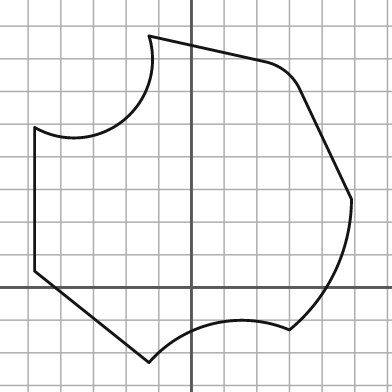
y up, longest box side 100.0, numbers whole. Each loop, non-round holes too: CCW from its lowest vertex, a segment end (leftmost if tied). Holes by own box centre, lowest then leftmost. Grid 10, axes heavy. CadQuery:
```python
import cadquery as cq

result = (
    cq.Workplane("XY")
    .moveTo(-13.0, -23.0)
    .threePointArc((7.0, -11.0), (30.0, -13.0))
    .threePointArc((44.0, 5.0), (49.0, 27.0))
    .lineTo(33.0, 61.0)
    .threePointArc((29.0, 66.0), (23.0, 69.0))
    .lineTo(-13.0, 77.0)
    .threePointArc((-21.0, 51.0), (-48.0, 49.0))
    .lineTo(-48.0, 5.0)
    .close()
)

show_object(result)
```